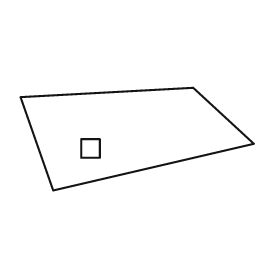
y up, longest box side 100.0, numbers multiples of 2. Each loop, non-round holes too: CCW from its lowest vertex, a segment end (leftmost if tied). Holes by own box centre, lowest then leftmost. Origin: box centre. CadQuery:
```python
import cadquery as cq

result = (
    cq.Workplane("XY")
    .moveTo(-36.0, -22.0)
    .lineTo(50.0, -2.0)
    .lineTo(24.0, 22.0)
    .lineTo(-50.0, 18.0)
    .close()
    .moveTo(-24.0, -8.0)
    .lineTo(-16.0, -8.0)
    .lineTo(-16.0, 0.0)
    .lineTo(-24.0, 0.0)
    .close()
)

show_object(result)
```